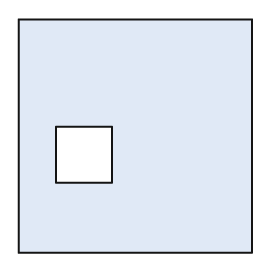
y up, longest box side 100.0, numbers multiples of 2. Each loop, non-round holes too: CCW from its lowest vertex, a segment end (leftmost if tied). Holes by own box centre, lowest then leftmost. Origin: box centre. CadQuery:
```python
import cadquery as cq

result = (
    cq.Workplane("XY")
    .moveTo(-50.0, -50.0)
    .lineTo(50.0, -50.0)
    .lineTo(50.0, 50.0)
    .lineTo(-50.0, 50.0)
    .close()
    .moveTo(-34.0, -20.0)
    .lineTo(-10.0, -20.0)
    .lineTo(-10.0, 4.0)
    .lineTo(-34.0, 4.0)
    .close()
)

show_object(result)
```